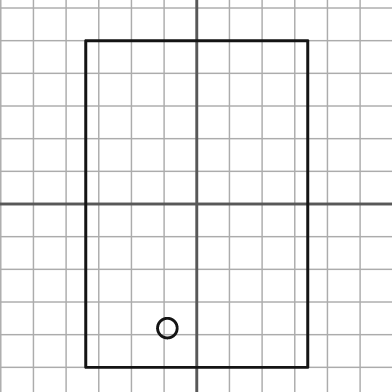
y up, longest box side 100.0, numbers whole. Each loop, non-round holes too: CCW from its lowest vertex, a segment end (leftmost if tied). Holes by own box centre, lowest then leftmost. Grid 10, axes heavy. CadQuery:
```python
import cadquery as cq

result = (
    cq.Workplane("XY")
    .moveTo(-34.0, -50.0)
    .lineTo(34.0, -50.0)
    .lineTo(34.0, 50.0)
    .lineTo(-34.0, 50.0)
    .close()
    .moveTo(-9.0, -38.0)
    .circle(3.0)
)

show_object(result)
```